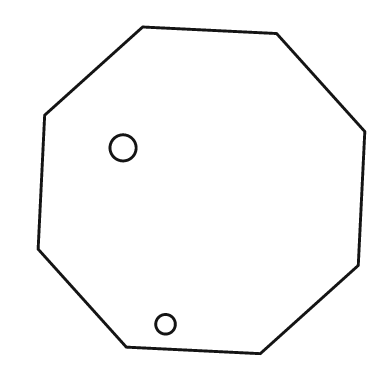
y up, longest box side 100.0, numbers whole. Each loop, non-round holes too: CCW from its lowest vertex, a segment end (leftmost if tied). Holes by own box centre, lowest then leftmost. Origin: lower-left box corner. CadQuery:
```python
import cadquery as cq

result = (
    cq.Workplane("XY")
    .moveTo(68.0, 0.0)
    .lineTo(98.0, 27.0)
    .lineTo(100.0, 68.0)
    .lineTo(73.0, 98.0)
    .lineTo(32.0, 100.0)
    .lineTo(2.0, 73.0)
    .lineTo(0.0, 32.0)
    .lineTo(27.0, 2.0)
    .close()
    .moveTo(39.0, 9.0)
    .circle(3.0)
    .moveTo(26.0, 63.0)
    .circle(4.0)
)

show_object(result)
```